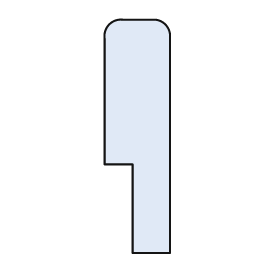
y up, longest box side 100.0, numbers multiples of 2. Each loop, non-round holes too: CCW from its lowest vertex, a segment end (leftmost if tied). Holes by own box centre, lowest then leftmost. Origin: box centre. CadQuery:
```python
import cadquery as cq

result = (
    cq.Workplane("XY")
    .moveTo(-2.0, -50.0)
    .lineTo(14.0, -50.0)
    .lineTo(14.0, 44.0)
    .threePointArc((12.0, 48.0), (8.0, 50.0))
    .lineTo(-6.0, 50.0)
    .threePointArc((-12.0, 48.0), (-14.0, 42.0))
    .lineTo(-14.0, -12.0)
    .lineTo(-2.0, -12.0)
    .close()
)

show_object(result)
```